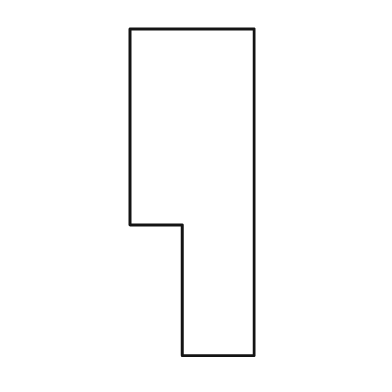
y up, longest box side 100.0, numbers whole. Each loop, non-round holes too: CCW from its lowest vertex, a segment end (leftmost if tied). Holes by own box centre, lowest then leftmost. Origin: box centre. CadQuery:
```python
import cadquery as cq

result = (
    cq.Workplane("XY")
    .moveTo(-3.0, -50.0)
    .lineTo(19.0, -50.0)
    .lineTo(19.0, 50.0)
    .lineTo(-19.0, 50.0)
    .lineTo(-19.0, -10.0)
    .lineTo(-3.0, -10.0)
    .close()
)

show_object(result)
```